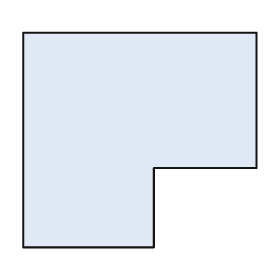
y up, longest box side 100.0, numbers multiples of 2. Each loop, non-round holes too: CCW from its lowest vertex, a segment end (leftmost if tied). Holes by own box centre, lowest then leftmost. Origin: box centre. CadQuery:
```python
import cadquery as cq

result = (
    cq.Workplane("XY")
    .moveTo(-50.0, -46.0)
    .lineTo(6.0, -46.0)
    .lineTo(6.0, -12.0)
    .lineTo(50.0, -12.0)
    .lineTo(50.0, 46.0)
    .lineTo(-50.0, 46.0)
    .close()
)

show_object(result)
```